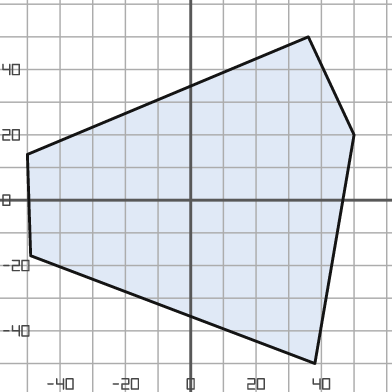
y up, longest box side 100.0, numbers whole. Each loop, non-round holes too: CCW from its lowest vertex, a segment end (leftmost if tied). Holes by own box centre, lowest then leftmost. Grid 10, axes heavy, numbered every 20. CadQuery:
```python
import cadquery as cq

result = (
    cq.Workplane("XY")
    .moveTo(38.0, -50.0)
    .lineTo(50.0, 20.0)
    .lineTo(36.0, 50.0)
    .lineTo(-50.0, 14.0)
    .lineTo(-49.0, -17.0)
    .close()
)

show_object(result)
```